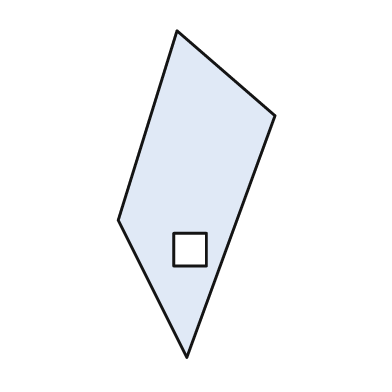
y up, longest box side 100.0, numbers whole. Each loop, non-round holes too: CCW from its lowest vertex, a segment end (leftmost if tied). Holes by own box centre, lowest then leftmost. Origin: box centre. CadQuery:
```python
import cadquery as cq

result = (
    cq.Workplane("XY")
    .moveTo(-3.0, -50.0)
    .lineTo(24.0, 24.0)
    .lineTo(-6.0, 50.0)
    .lineTo(-24.0, -8.0)
    .close()
    .moveTo(-7.0, -22.0)
    .lineTo(3.0, -22.0)
    .lineTo(3.0, -12.0)
    .lineTo(-7.0, -12.0)
    .close()
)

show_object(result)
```